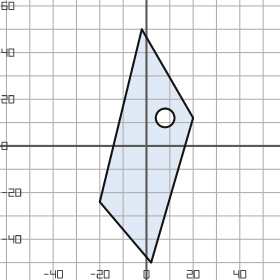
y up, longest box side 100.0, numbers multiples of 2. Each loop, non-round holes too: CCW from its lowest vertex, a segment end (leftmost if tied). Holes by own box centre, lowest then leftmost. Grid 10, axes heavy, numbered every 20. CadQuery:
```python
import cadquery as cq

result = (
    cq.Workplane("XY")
    .moveTo(2.0, -50.0)
    .lineTo(20.0, 12.0)
    .lineTo(-2.0, 50.0)
    .lineTo(-20.0, -24.0)
    .close()
    .moveTo(8.0, 12.0)
    .circle(4.0)
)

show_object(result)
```